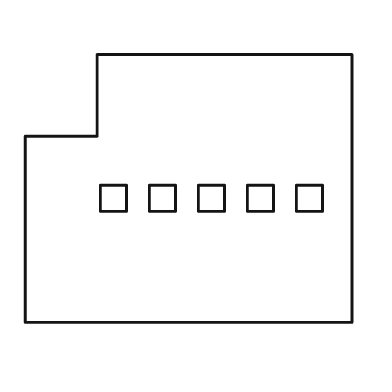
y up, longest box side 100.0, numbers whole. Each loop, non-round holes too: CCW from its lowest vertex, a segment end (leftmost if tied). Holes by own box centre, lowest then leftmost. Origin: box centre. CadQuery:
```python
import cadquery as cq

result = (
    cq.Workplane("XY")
    .moveTo(-50.0, -41.0)
    .lineTo(50.0, -41.0)
    .lineTo(50.0, 41.0)
    .lineTo(-28.0, 41.0)
    .lineTo(-28.0, 16.0)
    .lineTo(-50.0, 16.0)
    .close()
    .moveTo(-27.0, -7.0)
    .lineTo(-19.0, -7.0)
    .lineTo(-19.0, 1.0)
    .lineTo(-27.0, 1.0)
    .close()
    .moveTo(-12.0, -7.0)
    .lineTo(-4.0, -7.0)
    .lineTo(-4.0, 1.0)
    .lineTo(-12.0, 1.0)
    .close()
    .moveTo(3.0, -7.0)
    .lineTo(11.0, -7.0)
    .lineTo(11.0, 1.0)
    .lineTo(3.0, 1.0)
    .close()
    .moveTo(18.0, -7.0)
    .lineTo(26.0, -7.0)
    .lineTo(26.0, 1.0)
    .lineTo(18.0, 1.0)
    .close()
    .moveTo(33.0, -7.0)
    .lineTo(41.0, -7.0)
    .lineTo(41.0, 1.0)
    .lineTo(33.0, 1.0)
    .close()
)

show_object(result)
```